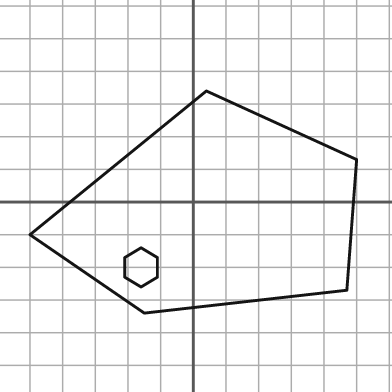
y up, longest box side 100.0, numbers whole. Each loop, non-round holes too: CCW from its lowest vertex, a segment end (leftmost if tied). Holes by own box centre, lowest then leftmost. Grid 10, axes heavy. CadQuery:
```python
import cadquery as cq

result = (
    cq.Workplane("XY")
    .moveTo(-15.0, -34.0)
    .lineTo(47.0, -27.0)
    .lineTo(50.0, 13.0)
    .lineTo(4.0, 34.0)
    .lineTo(-50.0, -10.0)
    .close()
    .moveTo(-16.0, -26.0)
    .lineTo(-11.0, -23.0)
    .lineTo(-11.0, -17.0)
    .lineTo(-16.0, -14.0)
    .lineTo(-21.0, -17.0)
    .lineTo(-21.0, -23.0)
    .close()
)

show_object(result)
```